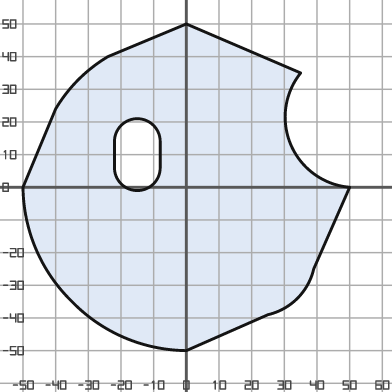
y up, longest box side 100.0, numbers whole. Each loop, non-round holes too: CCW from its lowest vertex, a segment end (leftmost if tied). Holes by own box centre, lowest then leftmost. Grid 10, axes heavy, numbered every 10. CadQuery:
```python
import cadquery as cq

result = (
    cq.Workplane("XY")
    .moveTo(0.0, -50.0)
    .lineTo(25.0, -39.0)
    .threePointArc((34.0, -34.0), (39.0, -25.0))
    .lineTo(50.0, 0.0)
    .threePointArc((32.0, 13.0), (35.0, 35.0))
    .lineTo(0.0, 50.0)
    .lineTo(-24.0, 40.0)
    .threePointArc((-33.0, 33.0), (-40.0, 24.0))
    .lineTo(-50.0, 0.0)
    .threePointArc((-46.0, -19.0), (-35.0, -35.0))
    .threePointArc((-19.0, -46.0), (0.0, -50.0))
    .close()
    .moveTo(-22.0, 6.0)
    .threePointArc((-15.0, -1.0), (-8.0, 6.0))
    .lineTo(-8.0, 14.0)
    .threePointArc((-15.0, 21.0), (-22.0, 14.0))
    .close()
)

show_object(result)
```